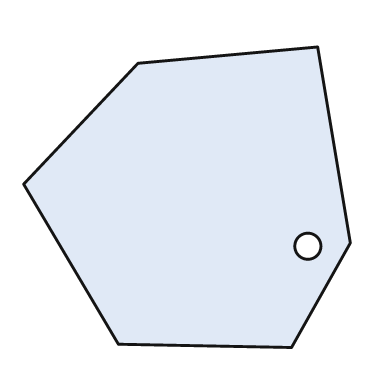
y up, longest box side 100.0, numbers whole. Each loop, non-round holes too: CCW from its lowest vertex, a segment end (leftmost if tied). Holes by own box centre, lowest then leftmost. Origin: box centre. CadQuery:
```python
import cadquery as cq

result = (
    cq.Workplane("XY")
    .moveTo(32.0, -46.0)
    .lineTo(50.0, -14.0)
    .lineTo(40.0, 46.0)
    .lineTo(-15.0, 41.0)
    .lineTo(-50.0, 4.0)
    .lineTo(-21.0, -45.0)
    .close()
    .moveTo(37.0, -15.0)
    .circle(4.0)
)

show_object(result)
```